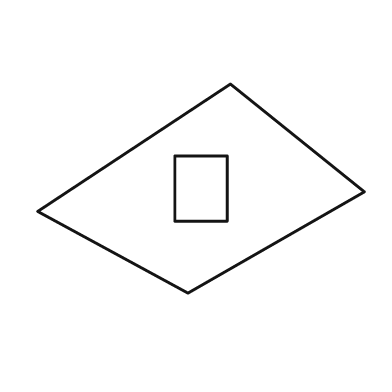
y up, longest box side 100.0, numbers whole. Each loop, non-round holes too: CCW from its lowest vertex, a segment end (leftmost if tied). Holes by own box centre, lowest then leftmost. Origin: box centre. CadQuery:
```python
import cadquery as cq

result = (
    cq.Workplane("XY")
    .moveTo(-4.0, -32.0)
    .lineTo(50.0, -1.0)
    .lineTo(9.0, 32.0)
    .lineTo(-50.0, -7.0)
    .close()
    .moveTo(-8.0, -10.0)
    .lineTo(8.0, -10.0)
    .lineTo(8.0, 10.0)
    .lineTo(-8.0, 10.0)
    .close()
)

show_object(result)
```